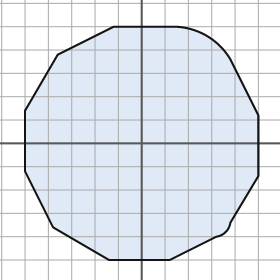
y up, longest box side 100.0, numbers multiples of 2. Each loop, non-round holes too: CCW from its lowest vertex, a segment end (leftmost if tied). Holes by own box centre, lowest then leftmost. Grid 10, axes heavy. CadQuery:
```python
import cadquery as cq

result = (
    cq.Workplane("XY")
    .moveTo(-14.0, -50.0)
    .lineTo(12.0, -50.0)
    .lineTo(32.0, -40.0)
    .threePointArc((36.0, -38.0), (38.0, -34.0))
    .lineTo(50.0, -14.0)
    .lineTo(50.0, 12.0)
    .lineTo(38.0, 36.0)
    .threePointArc((28.0, 46.0), (14.0, 50.0))
    .lineTo(-12.0, 50.0)
    .lineTo(-36.0, 38.0)
    .lineTo(-50.0, 14.0)
    .lineTo(-50.0, -12.0)
    .lineTo(-38.0, -36.0)
    .close()
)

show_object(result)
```